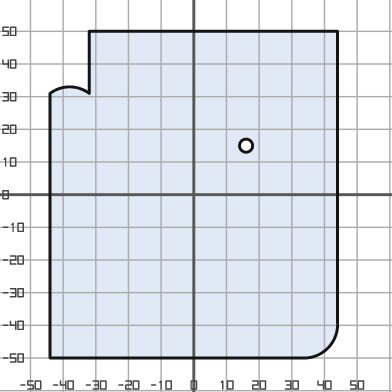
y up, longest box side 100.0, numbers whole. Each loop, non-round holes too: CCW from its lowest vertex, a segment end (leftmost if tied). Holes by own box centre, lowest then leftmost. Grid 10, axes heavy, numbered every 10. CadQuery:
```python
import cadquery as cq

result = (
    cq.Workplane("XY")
    .moveTo(-44.0, -50.0)
    .lineTo(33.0, -50.0)
    .threePointArc((41.0, -47.0), (44.0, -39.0))
    .lineTo(44.0, 50.0)
    .lineTo(-32.0, 50.0)
    .lineTo(-32.0, 31.0)
    .threePointArc((-38.0, 33.0), (-44.0, 31.0))
    .close()
    .moveTo(16.0, 15.0)
    .circle(2.0)
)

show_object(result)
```